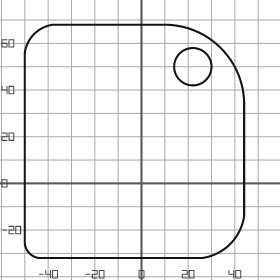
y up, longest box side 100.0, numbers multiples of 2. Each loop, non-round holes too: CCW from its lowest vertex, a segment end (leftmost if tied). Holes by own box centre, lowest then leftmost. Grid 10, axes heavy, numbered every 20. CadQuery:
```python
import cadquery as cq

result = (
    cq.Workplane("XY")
    .moveTo(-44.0, -32.0)
    .lineTo(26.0, -32.0)
    .threePointArc((38.0, -26.0), (44.0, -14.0))
    .lineTo(44.0, 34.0)
    .threePointArc((34.0, 58.0), (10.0, 68.0))
    .lineTo(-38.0, 68.0)
    .threePointArc((-46.0, 64.0), (-50.0, 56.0))
    .lineTo(-50.0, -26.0)
    .threePointArc((-48.0, -30.0), (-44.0, -32.0))
    .close()
    .moveTo(22.0, 50.0)
    .circle(8.0)
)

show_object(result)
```